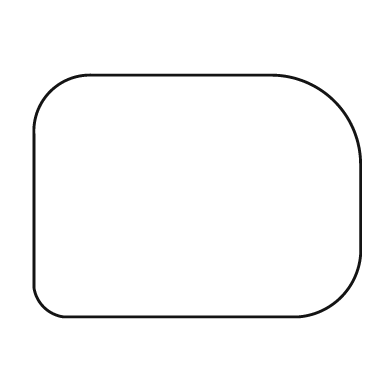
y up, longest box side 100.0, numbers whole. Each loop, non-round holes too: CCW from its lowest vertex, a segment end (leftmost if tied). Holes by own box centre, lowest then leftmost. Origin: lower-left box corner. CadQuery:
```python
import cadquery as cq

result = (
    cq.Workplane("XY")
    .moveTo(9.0, 0.0)
    .lineTo(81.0, 0.0)
    .threePointArc((94.0, 6.0), (100.0, 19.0))
    .lineTo(100.0, 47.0)
    .threePointArc((92.0, 66.0), (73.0, 74.0))
    .lineTo(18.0, 74.0)
    .threePointArc((5.0, 69.0), (0.0, 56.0))
    .lineTo(0.0, 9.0)
    .threePointArc((3.0, 3.0), (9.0, 0.0))
    .close()
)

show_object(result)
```